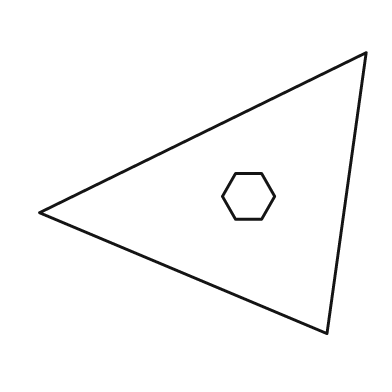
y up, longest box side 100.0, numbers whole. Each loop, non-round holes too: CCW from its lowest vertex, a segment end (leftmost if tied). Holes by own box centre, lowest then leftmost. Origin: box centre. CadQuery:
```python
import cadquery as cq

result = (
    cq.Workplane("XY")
    .moveTo(38.0, -43.0)
    .lineTo(50.0, 43.0)
    .lineTo(-50.0, -6.0)
    .close()
    .moveTo(10.0, -8.0)
    .lineTo(18.0, -8.0)
    .lineTo(22.0, -1.0)
    .lineTo(18.0, 6.0)
    .lineTo(10.0, 6.0)
    .lineTo(6.0, -1.0)
    .close()
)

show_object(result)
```